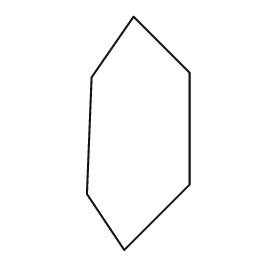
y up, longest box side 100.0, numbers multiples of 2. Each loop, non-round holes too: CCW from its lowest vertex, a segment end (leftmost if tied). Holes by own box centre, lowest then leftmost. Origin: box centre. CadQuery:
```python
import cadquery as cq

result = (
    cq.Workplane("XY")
    .moveTo(-6.0, -50.0)
    .lineTo(22.0, -22.0)
    .lineTo(22.0, 26.0)
    .lineTo(-2.0, 50.0)
    .lineTo(-20.0, 24.0)
    .lineTo(-22.0, -26.0)
    .close()
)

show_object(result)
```